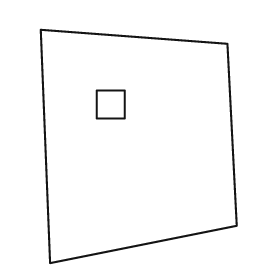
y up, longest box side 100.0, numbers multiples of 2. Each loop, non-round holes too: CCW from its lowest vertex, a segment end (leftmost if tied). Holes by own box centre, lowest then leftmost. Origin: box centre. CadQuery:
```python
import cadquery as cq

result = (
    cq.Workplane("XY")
    .moveTo(-38.0, -50.0)
    .lineTo(42.0, -34.0)
    .lineTo(38.0, 44.0)
    .lineTo(-42.0, 50.0)
    .close()
    .moveTo(-18.0, 12.0)
    .lineTo(-6.0, 12.0)
    .lineTo(-6.0, 24.0)
    .lineTo(-18.0, 24.0)
    .close()
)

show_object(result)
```